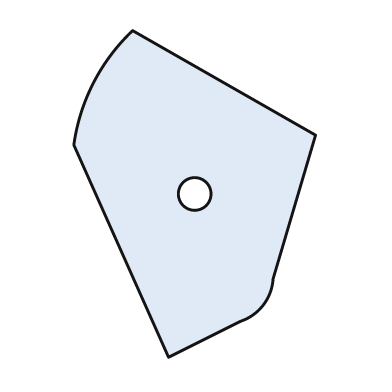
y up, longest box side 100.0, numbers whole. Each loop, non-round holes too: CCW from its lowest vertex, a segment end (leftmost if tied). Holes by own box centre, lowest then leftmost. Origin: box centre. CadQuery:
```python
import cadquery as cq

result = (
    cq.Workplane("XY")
    .moveTo(-8.0, -50.0)
    .lineTo(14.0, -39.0)
    .threePointArc((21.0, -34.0), (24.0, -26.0))
    .lineTo(37.0, 18.0)
    .lineTo(-19.0, 50.0)
    .threePointArc((-31.0, 34.0), (-37.0, 15.0))
    .close()
    .moveTo(0.0, 0.0)
    .circle(5.0)
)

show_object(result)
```